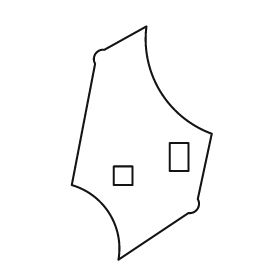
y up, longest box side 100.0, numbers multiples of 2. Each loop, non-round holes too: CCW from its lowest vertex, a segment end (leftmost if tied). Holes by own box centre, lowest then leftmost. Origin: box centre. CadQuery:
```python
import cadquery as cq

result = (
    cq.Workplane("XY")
    .moveTo(-10.0, -50.0)
    .lineTo(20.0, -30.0)
    .threePointArc((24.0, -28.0), (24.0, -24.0))
    .lineTo(30.0, 4.0)
    .threePointArc((8.0, 22.0), (2.0, 50.0))
    .lineTo(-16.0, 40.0)
    .threePointArc((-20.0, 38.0), (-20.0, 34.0))
    .lineTo(-30.0, -18.0)
    .threePointArc((-14.0, -30.0), (-10.0, -50.0))
    .close()
    .moveTo(-12.0, -18.0)
    .lineTo(-4.0, -18.0)
    .lineTo(-4.0, -10.0)
    .lineTo(-12.0, -10.0)
    .close()
    .moveTo(12.0, -12.0)
    .lineTo(20.0, -12.0)
    .lineTo(20.0, 0.0)
    .lineTo(12.0, 0.0)
    .close()
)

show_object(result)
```